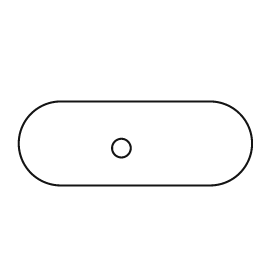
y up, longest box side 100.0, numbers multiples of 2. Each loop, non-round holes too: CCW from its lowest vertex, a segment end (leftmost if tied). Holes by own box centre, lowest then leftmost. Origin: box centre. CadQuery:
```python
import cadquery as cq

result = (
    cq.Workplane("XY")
    .moveTo(-32.0, -18.0)
    .lineTo(32.0, -18.0)
    .threePointArc((50.0, 0.0), (32.0, 18.0))
    .lineTo(-32.0, 18.0)
    .threePointArc((-50.0, 0.0), (-32.0, -18.0))
    .close()
    .moveTo(-6.0, -2.0)
    .circle(4.0)
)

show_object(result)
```